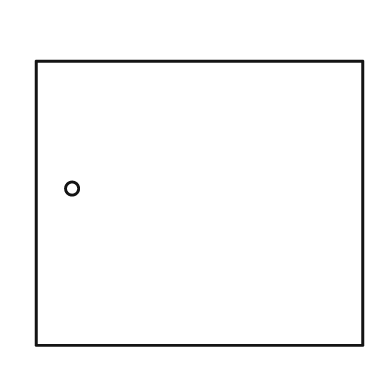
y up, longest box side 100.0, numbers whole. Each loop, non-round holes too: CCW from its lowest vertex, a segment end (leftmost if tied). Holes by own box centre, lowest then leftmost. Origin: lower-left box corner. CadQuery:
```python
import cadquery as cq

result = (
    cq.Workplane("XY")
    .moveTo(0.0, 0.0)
    .lineTo(100.0, 0.0)
    .lineTo(100.0, 87.0)
    .lineTo(0.0, 87.0)
    .close()
    .moveTo(11.0, 48.0)
    .circle(2.0)
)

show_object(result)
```